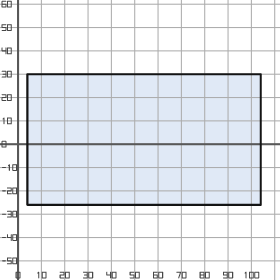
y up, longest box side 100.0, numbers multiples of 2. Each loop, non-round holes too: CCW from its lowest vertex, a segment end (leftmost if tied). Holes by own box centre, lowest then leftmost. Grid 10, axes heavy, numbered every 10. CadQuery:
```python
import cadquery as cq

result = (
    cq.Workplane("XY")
    .moveTo(4.0, -26.0)
    .lineTo(104.0, -26.0)
    .lineTo(104.0, 30.0)
    .lineTo(4.0, 30.0)
    .close()
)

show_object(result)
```